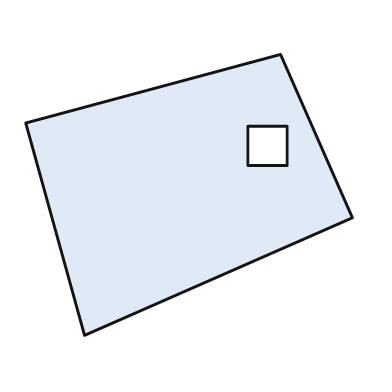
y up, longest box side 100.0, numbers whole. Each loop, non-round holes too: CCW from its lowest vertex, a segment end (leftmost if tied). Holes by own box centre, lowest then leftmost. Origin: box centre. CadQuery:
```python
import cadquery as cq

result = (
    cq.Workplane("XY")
    .moveTo(-32.0, -43.0)
    .lineTo(50.0, -7.0)
    .lineTo(28.0, 43.0)
    .lineTo(-50.0, 22.0)
    .close()
    .moveTo(18.0, 9.0)
    .lineTo(30.0, 9.0)
    .lineTo(30.0, 21.0)
    .lineTo(18.0, 21.0)
    .close()
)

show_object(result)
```